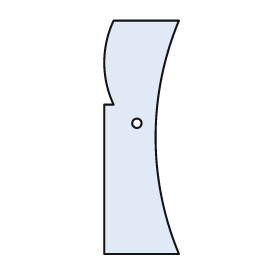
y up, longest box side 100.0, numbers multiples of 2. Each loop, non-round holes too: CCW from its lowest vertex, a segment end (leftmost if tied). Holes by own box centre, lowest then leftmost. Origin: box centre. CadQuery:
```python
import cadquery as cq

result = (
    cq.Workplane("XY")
    .moveTo(-16.0, -50.0)
    .lineTo(16.0, -50.0)
    .threePointArc((6.0, 0.0), (16.0, 50.0))
    .lineTo(-12.0, 50.0)
    .threePointArc((-16.0, 32.0), (-12.0, 14.0))
    .lineTo(-16.0, 14.0)
    .close()
    .moveTo(-2.0, 6.0)
    .circle(2.0)
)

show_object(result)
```